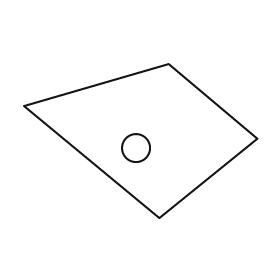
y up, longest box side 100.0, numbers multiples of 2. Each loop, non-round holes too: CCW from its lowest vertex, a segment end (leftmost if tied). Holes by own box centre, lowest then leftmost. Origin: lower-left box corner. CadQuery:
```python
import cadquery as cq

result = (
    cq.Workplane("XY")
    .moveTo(58.0, 0.0)
    .lineTo(100.0, 34.0)
    .lineTo(62.0, 66.0)
    .lineTo(0.0, 48.0)
    .close()
    .moveTo(48.0, 30.0)
    .circle(6.0)
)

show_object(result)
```